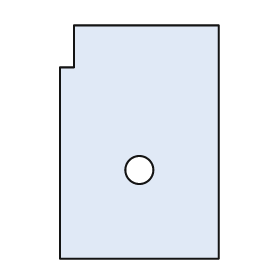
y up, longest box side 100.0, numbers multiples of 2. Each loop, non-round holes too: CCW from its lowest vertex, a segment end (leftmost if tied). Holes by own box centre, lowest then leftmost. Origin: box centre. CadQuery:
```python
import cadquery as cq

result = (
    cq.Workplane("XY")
    .moveTo(-34.0, -50.0)
    .lineTo(34.0, -50.0)
    .lineTo(34.0, 50.0)
    .lineTo(-28.0, 50.0)
    .lineTo(-28.0, 32.0)
    .lineTo(-34.0, 32.0)
    .close()
    .moveTo(0.0, -12.0)
    .circle(6.0)
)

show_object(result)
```